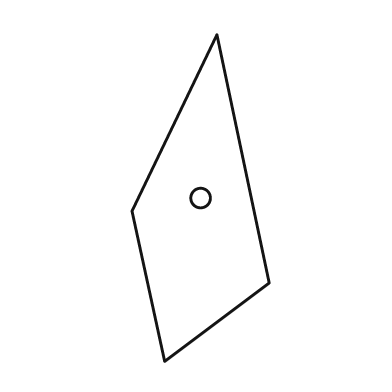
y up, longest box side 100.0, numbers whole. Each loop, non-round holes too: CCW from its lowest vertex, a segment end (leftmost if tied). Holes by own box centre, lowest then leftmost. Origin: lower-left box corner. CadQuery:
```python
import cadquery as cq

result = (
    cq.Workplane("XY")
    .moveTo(10.0, 0.0)
    .lineTo(42.0, 24.0)
    .lineTo(26.0, 100.0)
    .lineTo(0.0, 46.0)
    .close()
    .moveTo(21.0, 50.0)
    .circle(3.0)
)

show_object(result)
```